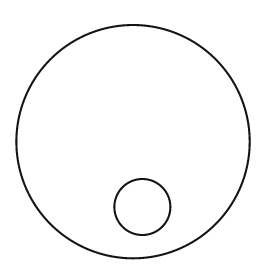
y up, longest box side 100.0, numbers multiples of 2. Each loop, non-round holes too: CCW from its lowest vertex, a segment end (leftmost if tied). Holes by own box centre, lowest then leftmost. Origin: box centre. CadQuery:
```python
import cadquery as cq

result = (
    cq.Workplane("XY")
    .moveTo(0.0, 0.0)
    .circle(50.0)
    .moveTo(4.0, -28.0)
    .circle(12.0)
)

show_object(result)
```